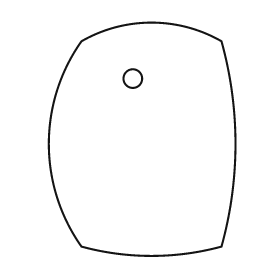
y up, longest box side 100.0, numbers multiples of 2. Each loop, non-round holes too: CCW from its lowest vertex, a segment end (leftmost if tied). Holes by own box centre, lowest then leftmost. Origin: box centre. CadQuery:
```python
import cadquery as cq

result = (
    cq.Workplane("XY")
    .moveTo(-26.0, -46.0)
    .threePointArc((4.0, -50.0), (34.0, -46.0))
    .threePointArc((40.0, -2.0), (34.0, 42.0))
    .threePointArc((4.0, 50.0), (-26.0, 42.0))
    .threePointArc((-40.0, -2.0), (-26.0, -46.0))
    .close()
    .moveTo(-4.0, 26.0)
    .circle(4.0)
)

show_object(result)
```